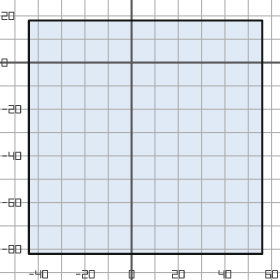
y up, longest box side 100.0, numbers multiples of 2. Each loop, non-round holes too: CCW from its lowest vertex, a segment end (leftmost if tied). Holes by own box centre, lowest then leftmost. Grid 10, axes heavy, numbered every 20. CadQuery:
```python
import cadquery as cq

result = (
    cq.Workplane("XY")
    .moveTo(-44.0, -82.0)
    .lineTo(56.0, -82.0)
    .lineTo(56.0, 18.0)
    .lineTo(-44.0, 18.0)
    .close()
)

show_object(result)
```